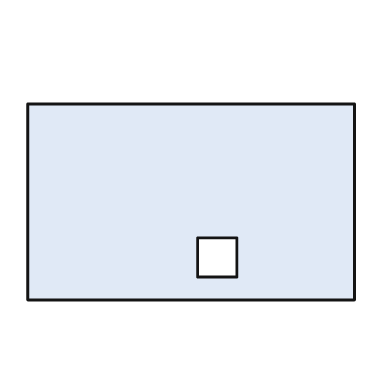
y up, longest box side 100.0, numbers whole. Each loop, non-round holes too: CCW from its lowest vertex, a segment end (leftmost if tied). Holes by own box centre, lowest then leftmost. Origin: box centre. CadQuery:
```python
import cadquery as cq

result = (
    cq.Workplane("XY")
    .moveTo(-50.0, -30.0)
    .lineTo(50.0, -30.0)
    .lineTo(50.0, 30.0)
    .lineTo(-50.0, 30.0)
    .close()
    .moveTo(2.0, -23.0)
    .lineTo(14.0, -23.0)
    .lineTo(14.0, -11.0)
    .lineTo(2.0, -11.0)
    .close()
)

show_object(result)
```